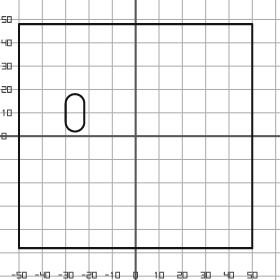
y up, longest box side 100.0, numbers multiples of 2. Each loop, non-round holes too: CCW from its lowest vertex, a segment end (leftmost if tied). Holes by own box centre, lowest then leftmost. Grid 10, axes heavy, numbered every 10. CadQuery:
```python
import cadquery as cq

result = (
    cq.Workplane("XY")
    .moveTo(-50.0, -48.0)
    .lineTo(50.0, -48.0)
    .lineTo(50.0, 48.0)
    .lineTo(-50.0, 48.0)
    .close()
    .moveTo(-30.0, 6.0)
    .threePointArc((-26.0, 2.0), (-22.0, 6.0))
    .lineTo(-22.0, 14.0)
    .threePointArc((-26.0, 18.0), (-30.0, 14.0))
    .close()
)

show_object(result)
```